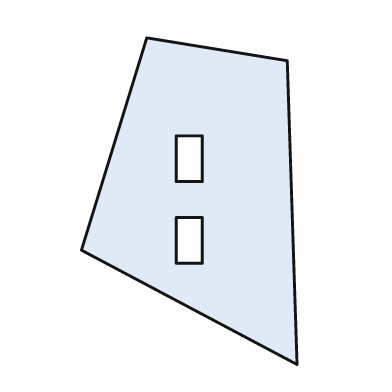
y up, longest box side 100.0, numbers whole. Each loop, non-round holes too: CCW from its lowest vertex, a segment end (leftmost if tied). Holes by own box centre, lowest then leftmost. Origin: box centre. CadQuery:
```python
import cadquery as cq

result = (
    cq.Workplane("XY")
    .moveTo(33.0, -50.0)
    .lineTo(30.0, 43.0)
    .lineTo(-13.0, 50.0)
    .lineTo(-33.0, -15.0)
    .close()
    .moveTo(-4.0, -19.0)
    .lineTo(4.0, -19.0)
    .lineTo(4.0, -5.0)
    .lineTo(-4.0, -5.0)
    .close()
    .moveTo(-4.0, 6.0)
    .lineTo(4.0, 6.0)
    .lineTo(4.0, 20.0)
    .lineTo(-4.0, 20.0)
    .close()
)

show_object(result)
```